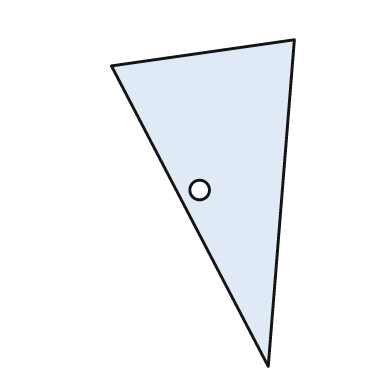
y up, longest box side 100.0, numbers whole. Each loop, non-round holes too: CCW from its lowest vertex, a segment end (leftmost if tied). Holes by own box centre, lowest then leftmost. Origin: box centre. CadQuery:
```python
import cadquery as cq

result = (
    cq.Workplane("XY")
    .moveTo(20.0, -50.0)
    .lineTo(28.0, 50.0)
    .lineTo(-28.0, 42.0)
    .close()
    .moveTo(-1.0, 4.0)
    .circle(3.0)
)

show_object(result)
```